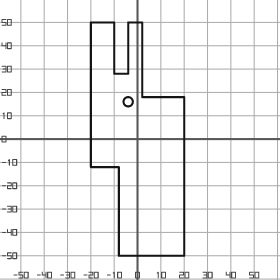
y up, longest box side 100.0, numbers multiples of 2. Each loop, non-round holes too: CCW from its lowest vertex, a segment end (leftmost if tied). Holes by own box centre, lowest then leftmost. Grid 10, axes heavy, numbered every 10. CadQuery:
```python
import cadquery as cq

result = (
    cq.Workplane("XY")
    .moveTo(-8.0, -50.0)
    .lineTo(20.0, -50.0)
    .lineTo(20.0, 18.0)
    .lineTo(2.0, 18.0)
    .lineTo(2.0, 50.0)
    .lineTo(-4.0, 50.0)
    .lineTo(-4.0, 28.0)
    .lineTo(-10.0, 28.0)
    .lineTo(-10.0, 50.0)
    .lineTo(-20.0, 50.0)
    .lineTo(-20.0, -12.0)
    .lineTo(-8.0, -12.0)
    .close()
    .moveTo(-4.0, 16.0)
    .circle(2.0)
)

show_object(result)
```